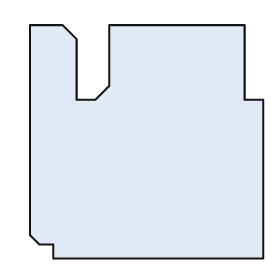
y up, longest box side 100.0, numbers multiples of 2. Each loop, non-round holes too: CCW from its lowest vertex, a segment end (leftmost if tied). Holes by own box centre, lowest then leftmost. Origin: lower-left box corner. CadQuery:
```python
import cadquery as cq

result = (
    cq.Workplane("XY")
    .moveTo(10.0, 0.0)
    .lineTo(100.0, 0.0)
    .lineTo(100.0, 68.0)
    .lineTo(92.0, 68.0)
    .lineTo(92.0, 100.0)
    .lineTo(34.0, 100.0)
    .lineTo(34.0, 74.0)
    .lineTo(28.0, 68.0)
    .lineTo(20.0, 68.0)
    .lineTo(20.0, 94.0)
    .lineTo(14.0, 100.0)
    .lineTo(0.0, 100.0)
    .lineTo(0.0, 10.0)
    .lineTo(4.0, 6.0)
    .lineTo(10.0, 6.0)
    .close()
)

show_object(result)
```